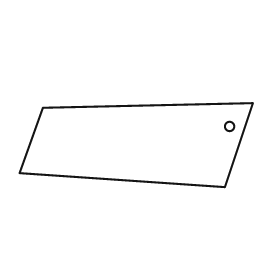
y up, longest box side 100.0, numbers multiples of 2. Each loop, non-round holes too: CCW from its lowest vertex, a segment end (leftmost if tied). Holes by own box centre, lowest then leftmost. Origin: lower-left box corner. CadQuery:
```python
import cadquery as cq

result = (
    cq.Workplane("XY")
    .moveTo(88.0, 0.0)
    .lineTo(100.0, 36.0)
    .lineTo(10.0, 34.0)
    .lineTo(0.0, 6.0)
    .close()
    .moveTo(90.0, 26.0)
    .circle(2.0)
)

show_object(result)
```